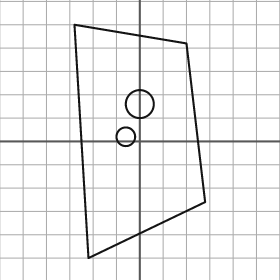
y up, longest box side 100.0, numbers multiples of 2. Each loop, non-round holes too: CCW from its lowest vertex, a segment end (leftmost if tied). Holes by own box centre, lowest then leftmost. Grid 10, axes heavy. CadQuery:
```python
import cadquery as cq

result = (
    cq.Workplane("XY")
    .moveTo(-22.0, -50.0)
    .lineTo(28.0, -26.0)
    .lineTo(20.0, 42.0)
    .lineTo(-28.0, 50.0)
    .close()
    .moveTo(-6.0, 2.0)
    .circle(4.0)
    .moveTo(0.0, 16.0)
    .circle(6.0)
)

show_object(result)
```